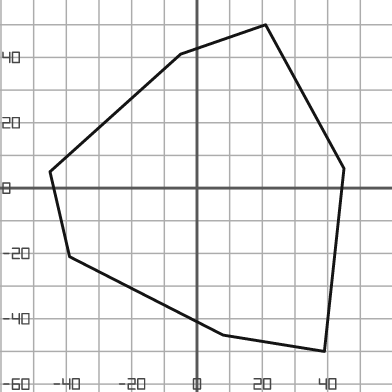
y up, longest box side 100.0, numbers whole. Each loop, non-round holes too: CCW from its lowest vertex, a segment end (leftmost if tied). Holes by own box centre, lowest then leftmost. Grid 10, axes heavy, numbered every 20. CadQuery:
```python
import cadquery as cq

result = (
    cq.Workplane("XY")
    .moveTo(39.0, -50.0)
    .lineTo(45.0, 6.0)
    .lineTo(21.0, 50.0)
    .lineTo(-5.0, 41.0)
    .lineTo(-45.0, 5.0)
    .lineTo(-39.0, -21.0)
    .lineTo(8.0, -45.0)
    .close()
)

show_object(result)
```